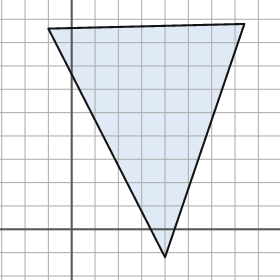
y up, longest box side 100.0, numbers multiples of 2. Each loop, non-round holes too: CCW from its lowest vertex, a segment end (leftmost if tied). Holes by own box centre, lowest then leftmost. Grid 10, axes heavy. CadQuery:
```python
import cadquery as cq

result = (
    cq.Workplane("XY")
    .moveTo(40.0, -12.0)
    .lineTo(74.0, 88.0)
    .lineTo(-10.0, 86.0)
    .close()
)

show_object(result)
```